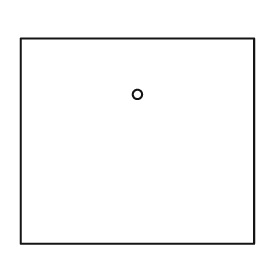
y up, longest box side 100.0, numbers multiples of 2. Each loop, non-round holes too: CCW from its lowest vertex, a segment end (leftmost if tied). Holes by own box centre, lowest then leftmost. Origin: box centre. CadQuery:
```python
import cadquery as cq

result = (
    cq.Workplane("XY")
    .moveTo(-50.0, -44.0)
    .lineTo(50.0, -44.0)
    .lineTo(50.0, 44.0)
    .lineTo(-50.0, 44.0)
    .close()
    .moveTo(0.0, 20.0)
    .circle(2.0)
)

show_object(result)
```